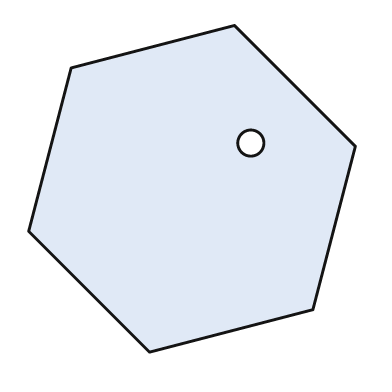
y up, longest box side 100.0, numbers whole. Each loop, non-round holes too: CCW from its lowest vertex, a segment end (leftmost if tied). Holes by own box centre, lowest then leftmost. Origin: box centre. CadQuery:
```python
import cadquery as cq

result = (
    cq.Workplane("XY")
    .moveTo(-13.0, -50.0)
    .lineTo(37.0, -37.0)
    .lineTo(50.0, 13.0)
    .lineTo(13.0, 50.0)
    .lineTo(-37.0, 37.0)
    .lineTo(-50.0, -13.0)
    .close()
    .moveTo(18.0, 14.0)
    .circle(4.0)
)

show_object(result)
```